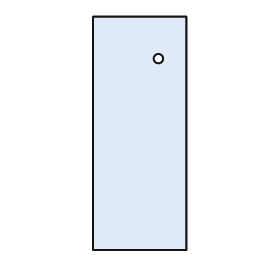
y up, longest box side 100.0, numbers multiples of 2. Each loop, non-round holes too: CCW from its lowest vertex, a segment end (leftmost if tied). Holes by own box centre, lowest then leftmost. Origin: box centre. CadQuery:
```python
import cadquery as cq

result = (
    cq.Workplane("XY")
    .moveTo(-20.0, -50.0)
    .lineTo(20.0, -50.0)
    .lineTo(20.0, 50.0)
    .lineTo(-20.0, 50.0)
    .close()
    .moveTo(8.0, 32.0)
    .circle(2.0)
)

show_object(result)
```